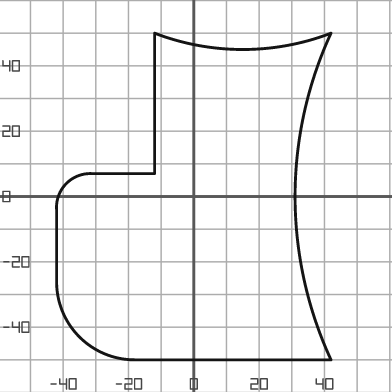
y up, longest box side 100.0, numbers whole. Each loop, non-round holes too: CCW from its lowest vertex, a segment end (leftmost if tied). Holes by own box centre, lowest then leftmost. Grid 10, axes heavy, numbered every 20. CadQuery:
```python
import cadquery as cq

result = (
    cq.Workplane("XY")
    .moveTo(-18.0, -50.0)
    .lineTo(42.0, -50.0)
    .threePointArc((31.0, 0.0), (42.0, 50.0))
    .threePointArc((15.0, 45.0), (-12.0, 50.0))
    .lineTo(-12.0, 7.0)
    .lineTo(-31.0, 7.0)
    .threePointArc((-39.0, 4.0), (-42.0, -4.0))
    .lineTo(-42.0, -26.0)
    .threePointArc((-35.0, -43.0), (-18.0, -50.0))
    .close()
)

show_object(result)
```